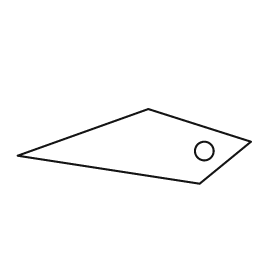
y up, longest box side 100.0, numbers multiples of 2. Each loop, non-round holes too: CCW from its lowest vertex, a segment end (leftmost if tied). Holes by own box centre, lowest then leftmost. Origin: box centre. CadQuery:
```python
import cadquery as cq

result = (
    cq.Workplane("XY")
    .moveTo(28.0, -16.0)
    .lineTo(50.0, 2.0)
    .lineTo(6.0, 16.0)
    .lineTo(-50.0, -4.0)
    .close()
    .moveTo(30.0, -2.0)
    .circle(4.0)
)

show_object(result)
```